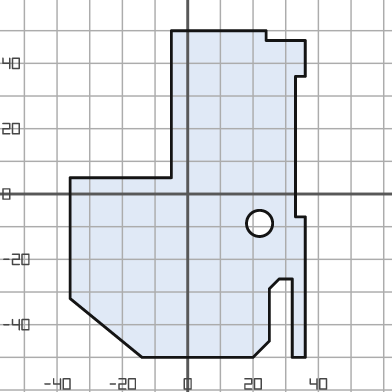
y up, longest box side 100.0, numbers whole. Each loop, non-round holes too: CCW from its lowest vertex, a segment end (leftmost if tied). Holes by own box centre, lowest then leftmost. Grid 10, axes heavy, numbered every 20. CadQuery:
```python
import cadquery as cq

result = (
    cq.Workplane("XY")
    .moveTo(-14.0, -50.0)
    .lineTo(20.0, -50.0)
    .lineTo(25.0, -45.0)
    .lineTo(25.0, -29.0)
    .lineTo(28.0, -26.0)
    .lineTo(32.0, -26.0)
    .lineTo(32.0, -50.0)
    .lineTo(36.0, -50.0)
    .lineTo(36.0, -7.0)
    .lineTo(33.0, -7.0)
    .lineTo(33.0, 36.0)
    .lineTo(36.0, 36.0)
    .lineTo(36.0, 47.0)
    .lineTo(24.0, 47.0)
    .lineTo(24.0, 50.0)
    .lineTo(-5.0, 50.0)
    .lineTo(-5.0, 5.0)
    .lineTo(-36.0, 5.0)
    .lineTo(-36.0, -32.0)
    .close()
    .moveTo(22.0, -9.0)
    .circle(4.0)
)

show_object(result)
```